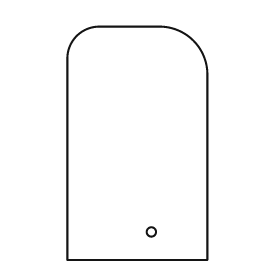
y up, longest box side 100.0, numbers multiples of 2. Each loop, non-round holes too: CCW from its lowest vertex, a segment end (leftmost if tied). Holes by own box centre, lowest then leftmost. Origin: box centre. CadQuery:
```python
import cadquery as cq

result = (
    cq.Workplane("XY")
    .moveTo(-30.0, -50.0)
    .lineTo(30.0, -50.0)
    .lineTo(30.0, 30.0)
    .threePointArc((24.0, 44.0), (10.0, 50.0))
    .lineTo(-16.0, 50.0)
    .threePointArc((-26.0, 46.0), (-30.0, 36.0))
    .close()
    .moveTo(6.0, -38.0)
    .circle(2.0)
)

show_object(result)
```